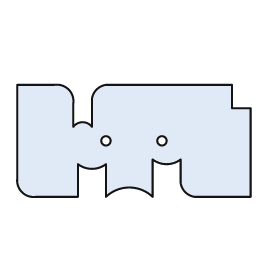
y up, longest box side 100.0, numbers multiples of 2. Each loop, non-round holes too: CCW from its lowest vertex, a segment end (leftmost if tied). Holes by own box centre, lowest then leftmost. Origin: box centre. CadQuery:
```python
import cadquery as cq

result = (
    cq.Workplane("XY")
    .moveTo(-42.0, -24.0)
    .lineTo(-24.0, -24.0)
    .lineTo(-24.0, -10.0)
    .threePointArc((-18.0, -12.0), (-12.0, -10.0))
    .lineTo(-12.0, -24.0)
    .threePointArc((-2.0, -20.0), (8.0, -24.0))
    .lineTo(8.0, -8.0)
    .threePointArc((14.0, -10.0), (20.0, -8.0))
    .lineTo(20.0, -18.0)
    .threePointArc((22.0, -22.0), (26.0, -24.0))
    .lineTo(50.0, -24.0)
    .lineTo(50.0, 14.0)
    .lineTo(42.0, 14.0)
    .lineTo(42.0, 24.0)
    .lineTo(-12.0, 24.0)
    .threePointArc((-16.0, 22.0), (-18.0, 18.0))
    .lineTo(-18.0, 6.0)
    .threePointArc((-22.0, 8.0), (-26.0, 6.0))
    .lineTo(-26.0, 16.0)
    .threePointArc((-28.0, 22.0), (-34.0, 24.0))
    .lineTo(-50.0, 24.0)
    .lineTo(-50.0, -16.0)
    .threePointArc((-48.0, -22.0), (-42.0, -24.0))
    .close()
    .moveTo(-12.0, 0.0)
    .circle(2.0)
    .moveTo(12.0, 0.0)
    .circle(2.0)
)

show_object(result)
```